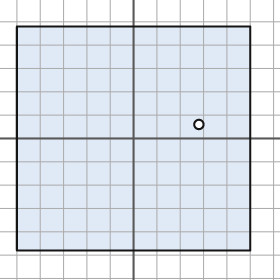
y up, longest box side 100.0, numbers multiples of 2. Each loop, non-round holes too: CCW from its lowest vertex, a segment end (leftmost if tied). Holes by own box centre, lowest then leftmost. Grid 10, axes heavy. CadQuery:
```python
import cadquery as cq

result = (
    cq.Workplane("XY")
    .moveTo(-50.0, -48.0)
    .lineTo(50.0, -48.0)
    .lineTo(50.0, 48.0)
    .lineTo(-50.0, 48.0)
    .close()
    .moveTo(28.0, 6.0)
    .circle(2.0)
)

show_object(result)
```